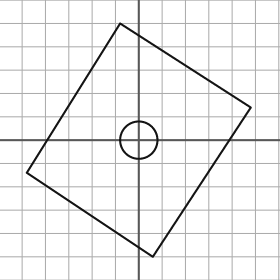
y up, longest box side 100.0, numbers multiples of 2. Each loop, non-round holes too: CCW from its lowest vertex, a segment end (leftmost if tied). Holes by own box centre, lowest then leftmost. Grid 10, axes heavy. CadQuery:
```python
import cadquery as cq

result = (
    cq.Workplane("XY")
    .moveTo(6.0, -50.0)
    .lineTo(48.0, 14.0)
    .lineTo(-8.0, 50.0)
    .lineTo(-48.0, -14.0)
    .close()
    .moveTo(0.0, 0.0)
    .circle(8.0)
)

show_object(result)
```